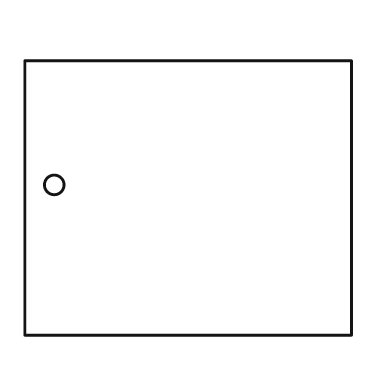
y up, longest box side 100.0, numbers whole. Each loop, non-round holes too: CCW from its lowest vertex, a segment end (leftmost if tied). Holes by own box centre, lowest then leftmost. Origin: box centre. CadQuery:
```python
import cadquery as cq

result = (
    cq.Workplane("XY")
    .moveTo(-50.0, -42.0)
    .lineTo(50.0, -42.0)
    .lineTo(50.0, 42.0)
    .lineTo(-50.0, 42.0)
    .close()
    .moveTo(-41.0, 4.0)
    .circle(3.0)
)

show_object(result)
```